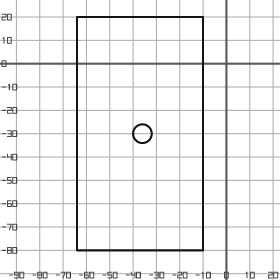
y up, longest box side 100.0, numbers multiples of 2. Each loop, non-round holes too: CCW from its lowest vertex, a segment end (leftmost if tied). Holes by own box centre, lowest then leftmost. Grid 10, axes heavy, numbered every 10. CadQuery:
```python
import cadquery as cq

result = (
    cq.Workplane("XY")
    .moveTo(-64.0, -80.0)
    .lineTo(-10.0, -80.0)
    .lineTo(-10.0, 20.0)
    .lineTo(-64.0, 20.0)
    .close()
    .moveTo(-36.0, -30.0)
    .circle(4.0)
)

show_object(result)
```